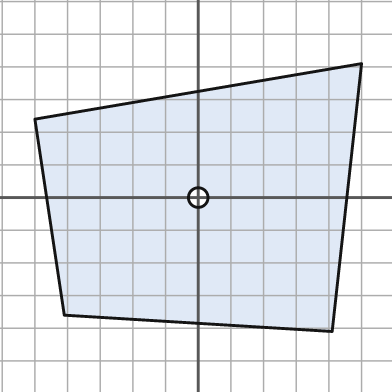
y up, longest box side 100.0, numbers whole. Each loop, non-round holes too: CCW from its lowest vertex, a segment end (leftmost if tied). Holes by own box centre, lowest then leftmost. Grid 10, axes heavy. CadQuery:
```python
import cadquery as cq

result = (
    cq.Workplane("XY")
    .moveTo(41.0, -41.0)
    .lineTo(50.0, 41.0)
    .lineTo(-50.0, 24.0)
    .lineTo(-41.0, -36.0)
    .close()
    .moveTo(0.0, 0.0)
    .circle(3.0)
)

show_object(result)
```